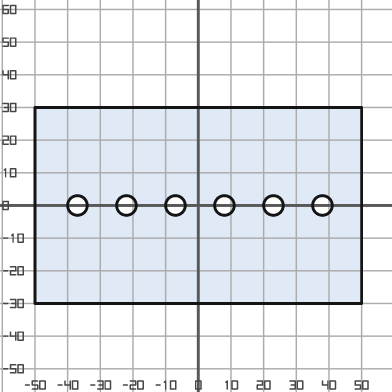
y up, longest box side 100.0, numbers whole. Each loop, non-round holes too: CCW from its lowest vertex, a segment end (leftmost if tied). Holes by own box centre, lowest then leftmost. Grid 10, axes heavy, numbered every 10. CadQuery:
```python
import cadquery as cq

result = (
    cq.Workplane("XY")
    .moveTo(-50.0, -30.0)
    .lineTo(50.0, -30.0)
    .lineTo(50.0, 30.0)
    .lineTo(-50.0, 30.0)
    .close()
    .moveTo(-37.0, 0.0)
    .circle(3.0)
    .moveTo(-22.0, 0.0)
    .circle(3.0)
    .moveTo(-7.0, 0.0)
    .circle(3.0)
    .moveTo(8.0, 0.0)
    .circle(3.0)
    .moveTo(23.0, 0.0)
    .circle(3.0)
    .moveTo(38.0, 0.0)
    .circle(3.0)
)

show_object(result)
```